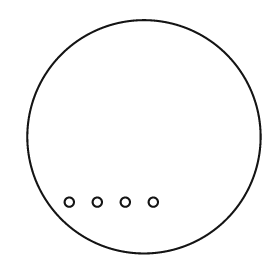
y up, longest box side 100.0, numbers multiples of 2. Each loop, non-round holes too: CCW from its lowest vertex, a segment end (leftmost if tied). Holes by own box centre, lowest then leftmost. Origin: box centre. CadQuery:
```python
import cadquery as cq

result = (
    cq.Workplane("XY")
    .moveTo(0.0, 0.0)
    .circle(50.0)
    .moveTo(-32.0, -28.0)
    .circle(2.0)
    .moveTo(-20.0, -28.0)
    .circle(2.0)
    .moveTo(-8.0, -28.0)
    .circle(2.0)
    .moveTo(4.0, -28.0)
    .circle(2.0)
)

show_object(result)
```